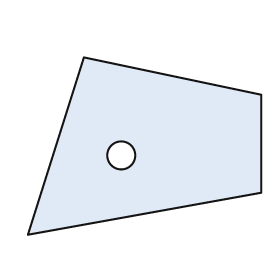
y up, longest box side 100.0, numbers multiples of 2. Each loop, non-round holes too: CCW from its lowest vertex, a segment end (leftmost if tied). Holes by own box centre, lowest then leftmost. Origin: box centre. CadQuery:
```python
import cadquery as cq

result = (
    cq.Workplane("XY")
    .moveTo(-50.0, -38.0)
    .lineTo(50.0, -20.0)
    .lineTo(50.0, 22.0)
    .lineTo(-26.0, 38.0)
    .close()
    .moveTo(-10.0, -4.0)
    .circle(6.0)
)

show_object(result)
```